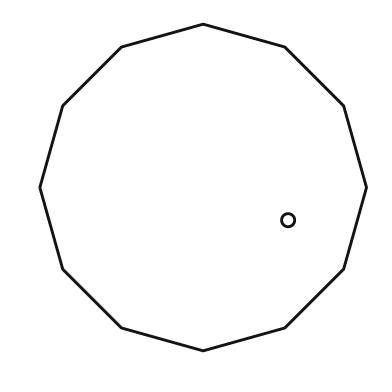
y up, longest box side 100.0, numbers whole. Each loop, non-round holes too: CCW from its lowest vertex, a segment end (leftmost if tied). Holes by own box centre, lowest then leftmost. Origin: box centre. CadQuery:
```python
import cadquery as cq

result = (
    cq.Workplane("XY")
    .moveTo(0.0, -50.0)
    .lineTo(25.0, -43.0)
    .lineTo(43.0, -25.0)
    .lineTo(50.0, 0.0)
    .lineTo(43.0, 25.0)
    .lineTo(25.0, 43.0)
    .lineTo(0.0, 50.0)
    .lineTo(-25.0, 43.0)
    .lineTo(-43.0, 25.0)
    .lineTo(-50.0, 0.0)
    .lineTo(-43.0, -25.0)
    .lineTo(-25.0, -43.0)
    .close()
    .moveTo(26.0, -10.0)
    .circle(2.0)
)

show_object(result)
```